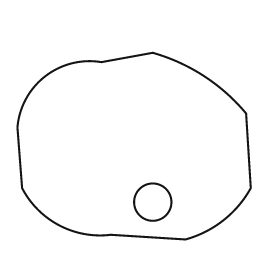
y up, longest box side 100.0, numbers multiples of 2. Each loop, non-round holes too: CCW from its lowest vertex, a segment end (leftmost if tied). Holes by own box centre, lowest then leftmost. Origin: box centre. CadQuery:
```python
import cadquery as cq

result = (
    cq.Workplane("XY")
    .moveTo(22.0, -40.0)
    .threePointArc((38.0, -32.0), (50.0, -18.0))
    .lineTo(48.0, 14.0)
    .threePointArc((30.0, 30.0), (8.0, 40.0))
    .lineTo(-14.0, 36.0)
    .threePointArc((-38.0, 30.0), (-50.0, 8.0))
    .lineTo(-48.0, -18.0)
    .threePointArc((-32.0, -34.0), (-10.0, -38.0))
    .close()
    .moveTo(8.0, -24.0)
    .circle(8.0)
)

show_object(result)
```